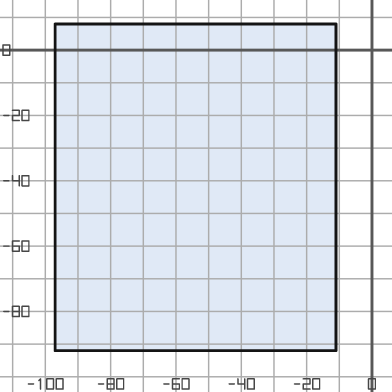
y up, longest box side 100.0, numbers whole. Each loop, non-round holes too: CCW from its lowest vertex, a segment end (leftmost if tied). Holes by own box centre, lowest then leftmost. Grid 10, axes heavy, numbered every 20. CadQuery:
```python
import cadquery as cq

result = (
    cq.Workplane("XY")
    .moveTo(-97.0, -92.0)
    .lineTo(-11.0, -92.0)
    .lineTo(-11.0, 8.0)
    .lineTo(-97.0, 8.0)
    .close()
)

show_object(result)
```